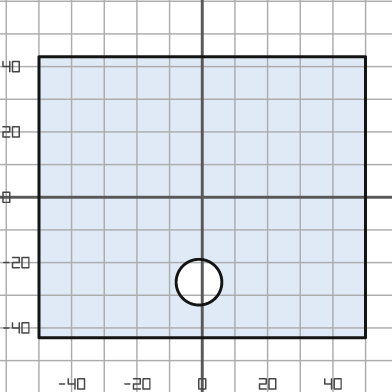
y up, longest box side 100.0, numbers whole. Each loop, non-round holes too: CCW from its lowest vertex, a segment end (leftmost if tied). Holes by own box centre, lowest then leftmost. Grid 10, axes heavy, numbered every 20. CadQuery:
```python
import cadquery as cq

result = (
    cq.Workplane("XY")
    .moveTo(-50.0, -43.0)
    .lineTo(50.0, -43.0)
    .lineTo(50.0, 43.0)
    .lineTo(-50.0, 43.0)
    .close()
    .moveTo(-1.0, -26.0)
    .circle(7.0)
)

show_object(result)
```